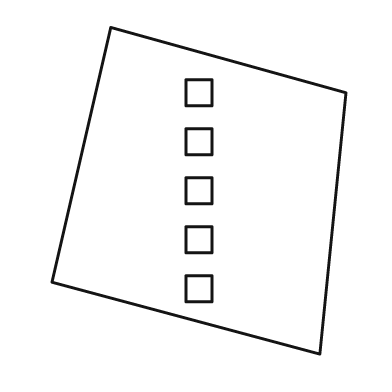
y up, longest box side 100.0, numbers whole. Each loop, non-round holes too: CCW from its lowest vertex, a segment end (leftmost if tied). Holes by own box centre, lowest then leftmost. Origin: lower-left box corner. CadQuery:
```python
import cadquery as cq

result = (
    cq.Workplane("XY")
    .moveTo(82.0, 0.0)
    .lineTo(90.0, 80.0)
    .lineTo(18.0, 100.0)
    .lineTo(0.0, 22.0)
    .close()
    .moveTo(41.0, 16.0)
    .lineTo(49.0, 16.0)
    .lineTo(49.0, 24.0)
    .lineTo(41.0, 24.0)
    .close()
    .moveTo(41.0, 31.0)
    .lineTo(49.0, 31.0)
    .lineTo(49.0, 39.0)
    .lineTo(41.0, 39.0)
    .close()
    .moveTo(41.0, 46.0)
    .lineTo(49.0, 46.0)
    .lineTo(49.0, 54.0)
    .lineTo(41.0, 54.0)
    .close()
    .moveTo(41.0, 61.0)
    .lineTo(49.0, 61.0)
    .lineTo(49.0, 69.0)
    .lineTo(41.0, 69.0)
    .close()
    .moveTo(41.0, 76.0)
    .lineTo(49.0, 76.0)
    .lineTo(49.0, 84.0)
    .lineTo(41.0, 84.0)
    .close()
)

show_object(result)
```